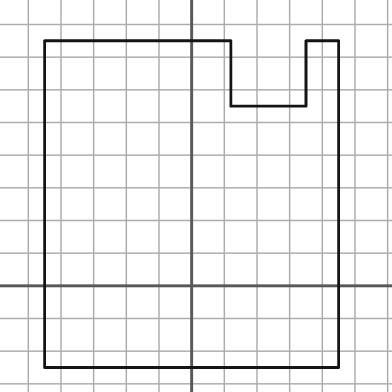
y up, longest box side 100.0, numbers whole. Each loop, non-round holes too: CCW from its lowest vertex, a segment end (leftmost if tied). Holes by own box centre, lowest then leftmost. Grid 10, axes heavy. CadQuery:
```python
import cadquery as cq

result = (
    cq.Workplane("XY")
    .moveTo(-45.0, -25.0)
    .lineTo(45.0, -25.0)
    .lineTo(45.0, 75.0)
    .lineTo(35.0, 75.0)
    .lineTo(35.0, 55.0)
    .lineTo(12.0, 55.0)
    .lineTo(12.0, 75.0)
    .lineTo(-45.0, 75.0)
    .close()
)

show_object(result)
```